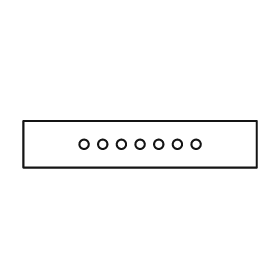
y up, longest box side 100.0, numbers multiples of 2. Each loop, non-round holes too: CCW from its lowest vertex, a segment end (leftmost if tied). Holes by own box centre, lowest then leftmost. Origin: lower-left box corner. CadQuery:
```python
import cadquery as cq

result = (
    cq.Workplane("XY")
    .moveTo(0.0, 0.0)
    .lineTo(100.0, 0.0)
    .lineTo(100.0, 20.0)
    .lineTo(0.0, 20.0)
    .close()
    .moveTo(26.0, 10.0)
    .circle(2.0)
    .moveTo(34.0, 10.0)
    .circle(2.0)
    .moveTo(42.0, 10.0)
    .circle(2.0)
    .moveTo(50.0, 10.0)
    .circle(2.0)
    .moveTo(58.0, 10.0)
    .circle(2.0)
    .moveTo(66.0, 10.0)
    .circle(2.0)
    .moveTo(74.0, 10.0)
    .circle(2.0)
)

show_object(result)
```